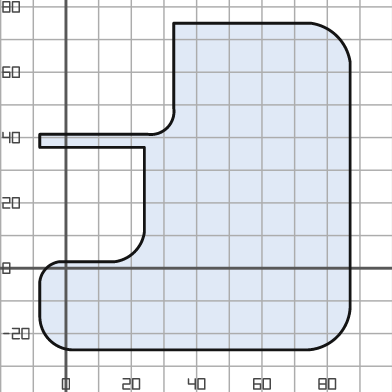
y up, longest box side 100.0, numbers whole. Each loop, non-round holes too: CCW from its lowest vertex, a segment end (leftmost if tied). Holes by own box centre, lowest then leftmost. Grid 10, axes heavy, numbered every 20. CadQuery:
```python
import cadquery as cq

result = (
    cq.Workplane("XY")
    .moveTo(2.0, -25.0)
    .lineTo(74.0, -25.0)
    .threePointArc((83.0, -21.0), (87.0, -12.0))
    .lineTo(87.0, 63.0)
    .threePointArc((83.0, 71.0), (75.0, 75.0))
    .lineTo(33.0, 75.0)
    .lineTo(33.0, 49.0)
    .threePointArc((31.0, 43.0), (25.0, 41.0))
    .lineTo(-8.0, 41.0)
    .lineTo(-8.0, 37.0)
    .lineTo(24.0, 37.0)
    .lineTo(24.0, 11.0)
    .threePointArc((21.0, 5.0), (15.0, 2.0))
    .lineTo(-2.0, 2.0)
    .threePointArc((-6.0, 0.0), (-8.0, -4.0))
    .lineTo(-8.0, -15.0)
    .threePointArc((-5.0, -22.0), (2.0, -25.0))
    .close()
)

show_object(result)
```